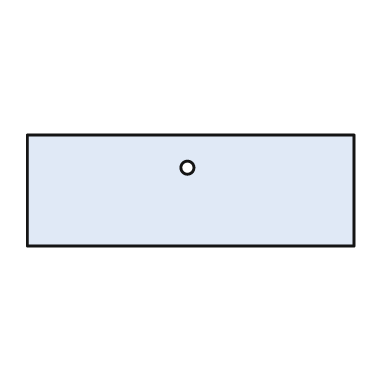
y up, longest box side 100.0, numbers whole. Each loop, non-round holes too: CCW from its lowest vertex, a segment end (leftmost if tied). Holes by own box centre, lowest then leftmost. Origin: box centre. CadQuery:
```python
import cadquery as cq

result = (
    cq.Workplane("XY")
    .moveTo(-50.0, -17.0)
    .lineTo(50.0, -17.0)
    .lineTo(50.0, 17.0)
    .lineTo(-50.0, 17.0)
    .close()
    .moveTo(-1.0, 7.0)
    .circle(2.0)
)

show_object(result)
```